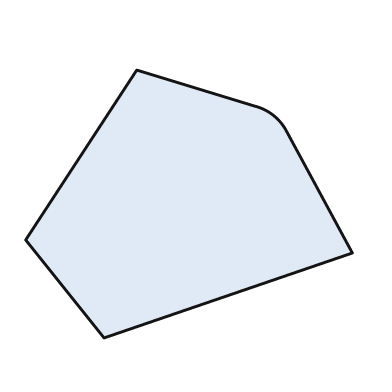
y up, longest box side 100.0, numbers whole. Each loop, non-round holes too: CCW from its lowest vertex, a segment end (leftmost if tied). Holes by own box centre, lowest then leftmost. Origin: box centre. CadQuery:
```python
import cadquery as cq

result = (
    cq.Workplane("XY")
    .moveTo(-26.0, -41.0)
    .lineTo(50.0, -15.0)
    .lineTo(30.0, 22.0)
    .threePointArc((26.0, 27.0), (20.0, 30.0))
    .lineTo(-16.0, 41.0)
    .lineTo(-50.0, -11.0)
    .close()
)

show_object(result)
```